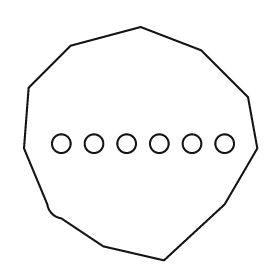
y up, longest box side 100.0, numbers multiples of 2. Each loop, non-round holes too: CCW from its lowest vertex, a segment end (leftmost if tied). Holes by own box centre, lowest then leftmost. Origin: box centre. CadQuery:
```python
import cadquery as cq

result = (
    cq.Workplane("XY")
    .moveTo(10.0, -50.0)
    .lineTo(36.0, -26.0)
    .lineTo(50.0, -2.0)
    .lineTo(46.0, 20.0)
    .lineTo(26.0, 40.0)
    .lineTo(0.0, 50.0)
    .lineTo(-30.0, 42.0)
    .lineTo(-48.0, 24.0)
    .lineTo(-50.0, -2.0)
    .lineTo(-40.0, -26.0)
    .threePointArc((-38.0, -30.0), (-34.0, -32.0))
    .lineTo(-16.0, -44.0)
    .close()
    .moveTo(-34.0, 0.0)
    .circle(4.0)
    .moveTo(-20.0, 0.0)
    .circle(4.0)
    .moveTo(-6.0, 0.0)
    .circle(4.0)
    .moveTo(8.0, 0.0)
    .circle(4.0)
    .moveTo(22.0, 0.0)
    .circle(4.0)
    .moveTo(36.0, 0.0)
    .circle(4.0)
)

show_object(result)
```